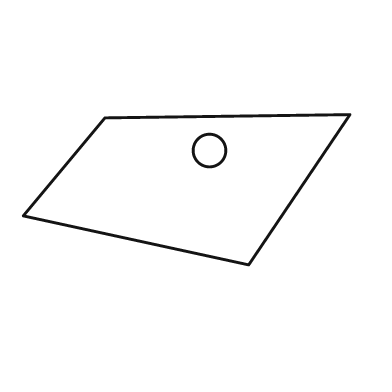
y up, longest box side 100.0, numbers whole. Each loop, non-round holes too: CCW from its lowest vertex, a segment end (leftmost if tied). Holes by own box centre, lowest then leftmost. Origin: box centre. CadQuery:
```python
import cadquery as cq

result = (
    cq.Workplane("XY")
    .moveTo(19.0, -23.0)
    .lineTo(50.0, 23.0)
    .lineTo(-25.0, 22.0)
    .lineTo(-50.0, -8.0)
    .close()
    .moveTo(7.0, 12.0)
    .circle(5.0)
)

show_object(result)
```